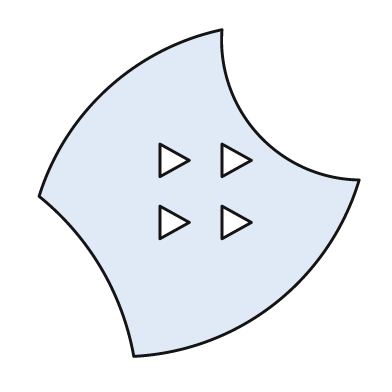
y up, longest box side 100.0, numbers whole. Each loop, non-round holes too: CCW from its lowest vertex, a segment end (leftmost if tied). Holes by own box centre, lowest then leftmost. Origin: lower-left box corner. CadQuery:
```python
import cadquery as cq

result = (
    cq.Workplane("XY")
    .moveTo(29.0, 0.0)
    .threePointArc((72.0, 16.0), (98.0, 54.0))
    .threePointArc((67.0, 68.0), (56.0, 100.0))
    .threePointArc((21.0, 82.0), (0.0, 49.0))
    .threePointArc((19.0, 27.0), (29.0, 0.0))
    .close()
    .moveTo(37.0, 36.0)
    .lineTo(46.0, 41.0)
    .lineTo(37.0, 46.0)
    .close()
    .moveTo(56.0, 36.0)
    .lineTo(65.0, 41.0)
    .lineTo(56.0, 46.0)
    .close()
    .moveTo(37.0, 55.0)
    .lineTo(46.0, 60.0)
    .lineTo(37.0, 65.0)
    .close()
    .moveTo(56.0, 55.0)
    .lineTo(65.0, 60.0)
    .lineTo(56.0, 65.0)
    .close()
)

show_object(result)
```